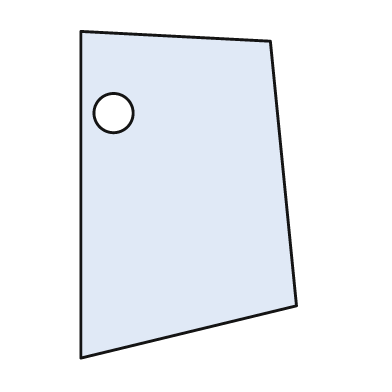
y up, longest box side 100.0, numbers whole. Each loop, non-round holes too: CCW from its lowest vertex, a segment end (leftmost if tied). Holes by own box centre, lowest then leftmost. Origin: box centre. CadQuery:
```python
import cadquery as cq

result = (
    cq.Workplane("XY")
    .moveTo(-33.0, -50.0)
    .lineTo(33.0, -34.0)
    .lineTo(25.0, 47.0)
    .lineTo(-33.0, 50.0)
    .close()
    .moveTo(-23.0, 25.0)
    .circle(6.0)
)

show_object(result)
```